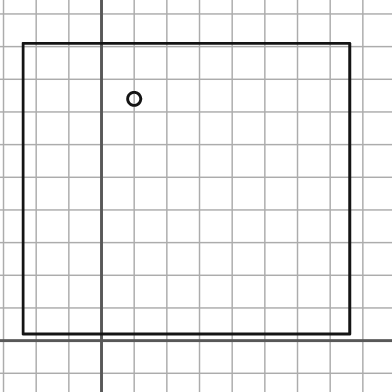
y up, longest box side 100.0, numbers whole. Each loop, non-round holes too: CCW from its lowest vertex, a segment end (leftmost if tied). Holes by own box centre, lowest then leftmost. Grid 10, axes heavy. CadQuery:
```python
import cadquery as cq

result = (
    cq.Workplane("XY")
    .moveTo(-24.0, 2.0)
    .lineTo(76.0, 2.0)
    .lineTo(76.0, 91.0)
    .lineTo(-24.0, 91.0)
    .close()
    .moveTo(10.0, 74.0)
    .circle(2.0)
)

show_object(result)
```